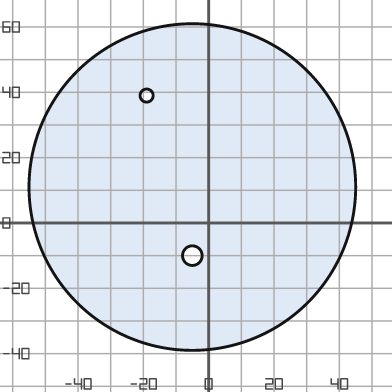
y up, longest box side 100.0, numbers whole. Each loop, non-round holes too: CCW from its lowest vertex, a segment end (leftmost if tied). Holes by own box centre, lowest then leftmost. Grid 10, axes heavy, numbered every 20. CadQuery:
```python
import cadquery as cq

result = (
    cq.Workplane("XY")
    .moveTo(-5.0, 11.0)
    .circle(50.0)
    .moveTo(-5.0, -10.0)
    .circle(3.0)
    .moveTo(-19.0, 39.0)
    .circle(2.0)
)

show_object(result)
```